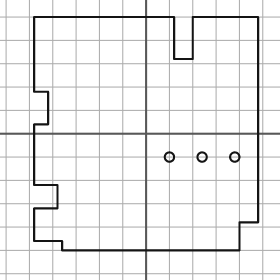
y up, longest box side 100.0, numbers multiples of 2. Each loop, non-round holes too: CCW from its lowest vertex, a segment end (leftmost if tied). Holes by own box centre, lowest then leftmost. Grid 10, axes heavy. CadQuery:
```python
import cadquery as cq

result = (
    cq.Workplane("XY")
    .moveTo(-36.0, -50.0)
    .lineTo(40.0, -50.0)
    .lineTo(40.0, -38.0)
    .lineTo(48.0, -38.0)
    .lineTo(48.0, 50.0)
    .lineTo(20.0, 50.0)
    .lineTo(20.0, 32.0)
    .lineTo(12.0, 32.0)
    .lineTo(12.0, 50.0)
    .lineTo(-48.0, 50.0)
    .lineTo(-48.0, 18.0)
    .lineTo(-42.0, 18.0)
    .lineTo(-42.0, 4.0)
    .lineTo(-48.0, 4.0)
    .lineTo(-48.0, -22.0)
    .lineTo(-38.0, -22.0)
    .lineTo(-38.0, -32.0)
    .lineTo(-48.0, -32.0)
    .lineTo(-48.0, -46.0)
    .lineTo(-36.0, -46.0)
    .close()
    .moveTo(10.0, -10.0)
    .circle(2.0)
    .moveTo(24.0, -10.0)
    .circle(2.0)
    .moveTo(38.0, -10.0)
    .circle(2.0)
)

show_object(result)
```